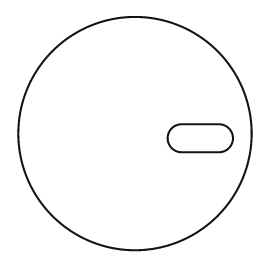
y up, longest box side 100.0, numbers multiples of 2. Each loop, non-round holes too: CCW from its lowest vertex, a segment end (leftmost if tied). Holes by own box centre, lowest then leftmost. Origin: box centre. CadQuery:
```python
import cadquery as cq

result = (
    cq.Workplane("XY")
    .moveTo(0.0, 0.0)
    .circle(50.0)
    .moveTo(20.0, -8.0)
    .lineTo(36.0, -8.0)
    .threePointArc((42.0, -2.0), (36.0, 4.0))
    .lineTo(20.0, 4.0)
    .threePointArc((14.0, -2.0), (20.0, -8.0))
    .close()
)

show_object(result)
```